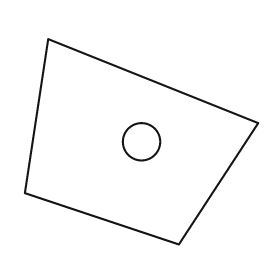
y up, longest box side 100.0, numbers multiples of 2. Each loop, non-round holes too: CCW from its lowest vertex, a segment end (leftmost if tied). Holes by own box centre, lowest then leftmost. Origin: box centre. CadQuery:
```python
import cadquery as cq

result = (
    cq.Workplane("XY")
    .moveTo(16.0, -44.0)
    .lineTo(50.0, 8.0)
    .lineTo(-40.0, 44.0)
    .lineTo(-50.0, -22.0)
    .close()
    .moveTo(0.0, 0.0)
    .circle(8.0)
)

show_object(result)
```